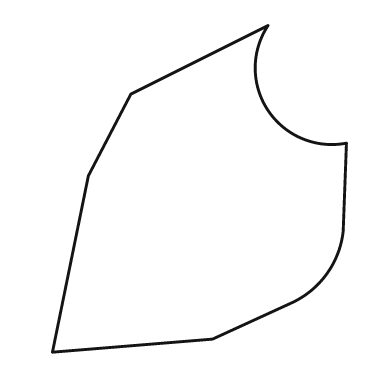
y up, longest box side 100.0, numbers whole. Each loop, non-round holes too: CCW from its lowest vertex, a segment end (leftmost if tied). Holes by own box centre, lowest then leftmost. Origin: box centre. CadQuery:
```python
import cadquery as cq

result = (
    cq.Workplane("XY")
    .moveTo(-45.0, -50.0)
    .lineTo(4.0, -46.0)
    .lineTo(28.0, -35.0)
    .threePointArc((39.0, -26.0), (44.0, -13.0))
    .lineTo(45.0, 14.0)
    .threePointArc((21.0, 24.0), (21.0, 50.0))
    .lineTo(-21.0, 29.0)
    .lineTo(-34.0, 4.0)
    .close()
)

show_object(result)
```